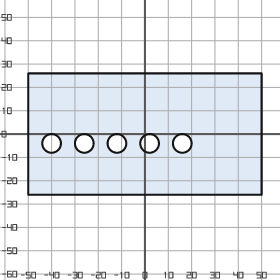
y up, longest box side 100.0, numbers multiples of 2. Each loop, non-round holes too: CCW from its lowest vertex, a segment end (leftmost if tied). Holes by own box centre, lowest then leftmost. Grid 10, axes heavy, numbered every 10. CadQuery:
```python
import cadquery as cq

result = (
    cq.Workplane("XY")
    .moveTo(-50.0, -26.0)
    .lineTo(50.0, -26.0)
    .lineTo(50.0, 26.0)
    .lineTo(-50.0, 26.0)
    .close()
    .moveTo(-40.0, -4.0)
    .circle(4.0)
    .moveTo(-26.0, -4.0)
    .circle(4.0)
    .moveTo(-12.0, -4.0)
    .circle(4.0)
    .moveTo(2.0, -4.0)
    .circle(4.0)
    .moveTo(16.0, -4.0)
    .circle(4.0)
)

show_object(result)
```